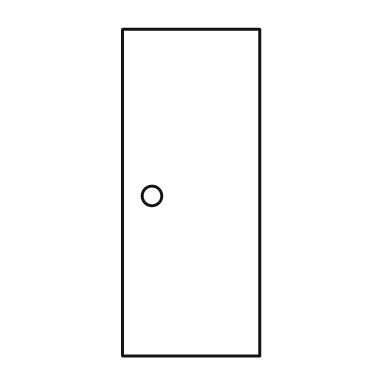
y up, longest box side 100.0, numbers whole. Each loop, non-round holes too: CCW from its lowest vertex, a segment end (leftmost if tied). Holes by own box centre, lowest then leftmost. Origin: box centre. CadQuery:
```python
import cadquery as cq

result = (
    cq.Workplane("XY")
    .moveTo(-21.0, -50.0)
    .lineTo(21.0, -50.0)
    .lineTo(21.0, 50.0)
    .lineTo(-21.0, 50.0)
    .close()
    .moveTo(-12.0, -1.0)
    .circle(3.0)
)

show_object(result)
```